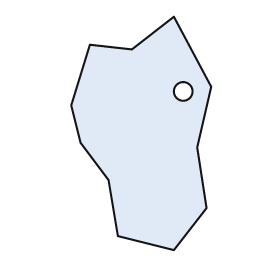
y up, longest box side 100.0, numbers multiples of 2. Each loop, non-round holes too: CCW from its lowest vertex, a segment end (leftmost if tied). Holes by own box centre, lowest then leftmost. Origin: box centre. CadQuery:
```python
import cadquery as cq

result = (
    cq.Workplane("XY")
    .moveTo(14.0, -50.0)
    .lineTo(28.0, -32.0)
    .lineTo(24.0, -6.0)
    .lineTo(30.0, 20.0)
    .lineTo(14.0, 50.0)
    .lineTo(-4.0, 36.0)
    .lineTo(-22.0, 38.0)
    .lineTo(-30.0, 12.0)
    .lineTo(-26.0, -4.0)
    .lineTo(-14.0, -20.0)
    .lineTo(-10.0, -44.0)
    .close()
    .moveTo(18.0, 18.0)
    .circle(4.0)
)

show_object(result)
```